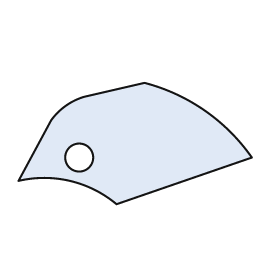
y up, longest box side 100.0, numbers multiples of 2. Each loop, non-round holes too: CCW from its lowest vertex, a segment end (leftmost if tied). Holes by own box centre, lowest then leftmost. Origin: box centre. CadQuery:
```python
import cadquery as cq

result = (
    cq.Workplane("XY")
    .moveTo(-8.0, -26.0)
    .lineTo(50.0, -6.0)
    .threePointArc((30.0, 14.0), (4.0, 26.0))
    .lineTo(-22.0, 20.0)
    .threePointArc((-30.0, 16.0), (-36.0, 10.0))
    .lineTo(-50.0, -16.0)
    .threePointArc((-28.0, -16.0), (-8.0, -26.0))
    .close()
    .moveTo(-24.0, -6.0)
    .circle(6.0)
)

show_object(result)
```